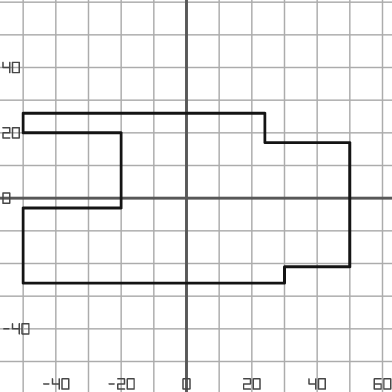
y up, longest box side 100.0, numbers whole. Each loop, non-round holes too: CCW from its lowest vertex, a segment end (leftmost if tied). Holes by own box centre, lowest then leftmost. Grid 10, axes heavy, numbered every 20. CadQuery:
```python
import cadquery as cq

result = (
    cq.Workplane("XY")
    .moveTo(-50.0, -26.0)
    .lineTo(30.0, -26.0)
    .lineTo(30.0, -21.0)
    .lineTo(50.0, -21.0)
    .lineTo(50.0, 17.0)
    .lineTo(24.0, 17.0)
    .lineTo(24.0, 26.0)
    .lineTo(-50.0, 26.0)
    .lineTo(-50.0, 20.0)
    .lineTo(-20.0, 20.0)
    .lineTo(-20.0, -3.0)
    .lineTo(-50.0, -3.0)
    .close()
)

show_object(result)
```